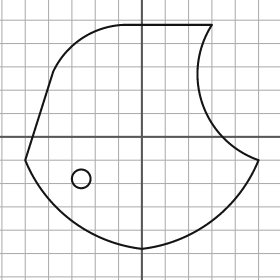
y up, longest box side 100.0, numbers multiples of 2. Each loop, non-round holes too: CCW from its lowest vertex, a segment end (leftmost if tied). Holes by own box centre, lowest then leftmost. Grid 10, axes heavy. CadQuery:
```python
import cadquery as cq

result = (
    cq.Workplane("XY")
    .moveTo(0.0, -48.0)
    .threePointArc((30.0, -36.0), (50.0, -10.0))
    .threePointArc((26.0, 14.0), (30.0, 48.0))
    .lineTo(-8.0, 48.0)
    .threePointArc((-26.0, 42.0), (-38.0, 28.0))
    .lineTo(-50.0, -10.0)
    .threePointArc((-30.0, -36.0), (0.0, -48.0))
    .close()
    .moveTo(-26.0, -18.0)
    .circle(4.0)
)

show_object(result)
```